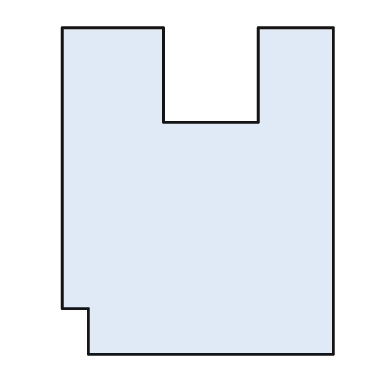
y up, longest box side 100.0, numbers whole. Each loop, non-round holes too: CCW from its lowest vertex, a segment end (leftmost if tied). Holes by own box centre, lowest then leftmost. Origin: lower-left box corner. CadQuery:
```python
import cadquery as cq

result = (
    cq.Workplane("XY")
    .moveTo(8.0, 0.0)
    .lineTo(83.0, 0.0)
    .lineTo(83.0, 100.0)
    .lineTo(60.0, 100.0)
    .lineTo(60.0, 71.0)
    .lineTo(31.0, 71.0)
    .lineTo(31.0, 100.0)
    .lineTo(0.0, 100.0)
    .lineTo(0.0, 14.0)
    .lineTo(8.0, 14.0)
    .close()
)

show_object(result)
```